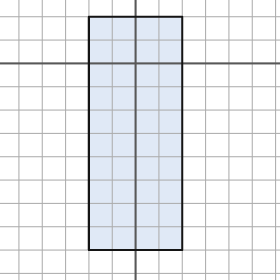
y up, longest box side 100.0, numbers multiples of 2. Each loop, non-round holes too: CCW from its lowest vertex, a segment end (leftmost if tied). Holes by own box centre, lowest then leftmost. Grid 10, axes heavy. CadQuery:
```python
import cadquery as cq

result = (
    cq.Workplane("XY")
    .moveTo(-20.0, -80.0)
    .lineTo(20.0, -80.0)
    .lineTo(20.0, 20.0)
    .lineTo(-20.0, 20.0)
    .close()
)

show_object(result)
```